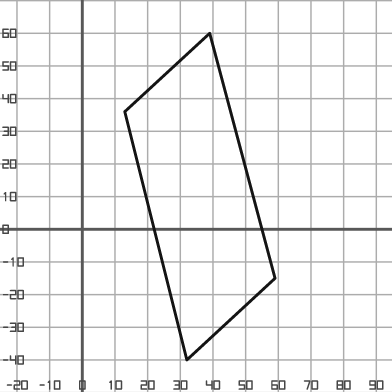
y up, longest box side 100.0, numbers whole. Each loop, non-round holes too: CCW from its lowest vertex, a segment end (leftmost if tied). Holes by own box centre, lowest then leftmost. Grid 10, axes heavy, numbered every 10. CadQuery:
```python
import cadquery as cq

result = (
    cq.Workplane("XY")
    .moveTo(32.0, -40.0)
    .lineTo(59.0, -15.0)
    .lineTo(39.0, 60.0)
    .lineTo(13.0, 36.0)
    .close()
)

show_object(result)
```